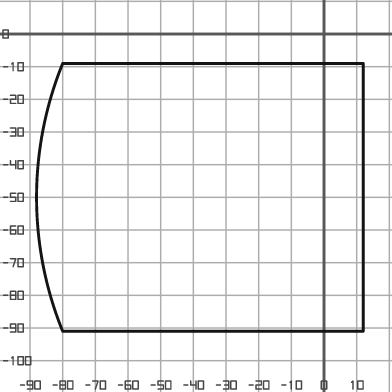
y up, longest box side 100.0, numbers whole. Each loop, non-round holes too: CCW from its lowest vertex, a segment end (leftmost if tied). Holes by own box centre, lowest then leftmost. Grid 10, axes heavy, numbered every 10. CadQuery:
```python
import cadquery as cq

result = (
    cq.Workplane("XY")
    .moveTo(-80.0, -91.0)
    .lineTo(12.0, -91.0)
    .lineTo(12.0, -9.0)
    .lineTo(-80.0, -9.0)
    .threePointArc((-88.0, -50.0), (-80.0, -91.0))
    .close()
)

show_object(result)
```